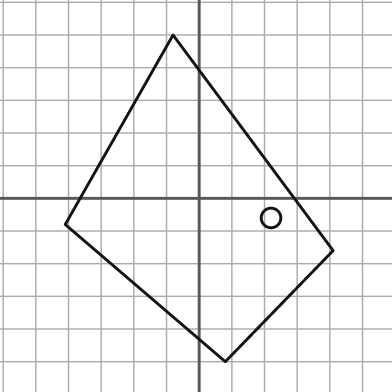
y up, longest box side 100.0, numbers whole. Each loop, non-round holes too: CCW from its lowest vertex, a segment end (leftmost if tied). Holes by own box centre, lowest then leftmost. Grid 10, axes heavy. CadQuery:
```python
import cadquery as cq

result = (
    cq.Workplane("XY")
    .moveTo(8.0, -50.0)
    .lineTo(41.0, -16.0)
    .lineTo(-8.0, 50.0)
    .lineTo(-41.0, -8.0)
    .close()
    .moveTo(22.0, -6.0)
    .circle(3.0)
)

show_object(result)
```